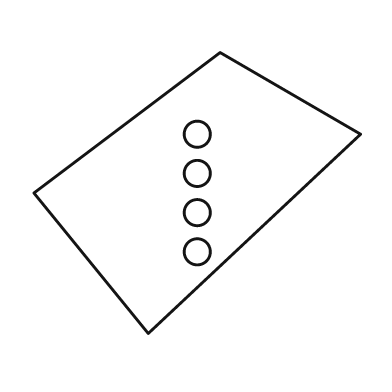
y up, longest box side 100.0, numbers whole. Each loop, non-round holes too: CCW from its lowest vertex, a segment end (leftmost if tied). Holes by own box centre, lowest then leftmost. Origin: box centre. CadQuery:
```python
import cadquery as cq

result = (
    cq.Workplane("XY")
    .moveTo(-15.0, -43.0)
    .lineTo(50.0, 18.0)
    .lineTo(7.0, 43.0)
    .lineTo(-50.0, 0.0)
    .close()
    .moveTo(0.0, -18.0)
    .circle(4.0)
    .moveTo(0.0, -6.0)
    .circle(4.0)
    .moveTo(0.0, 6.0)
    .circle(4.0)
    .moveTo(0.0, 18.0)
    .circle(4.0)
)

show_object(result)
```